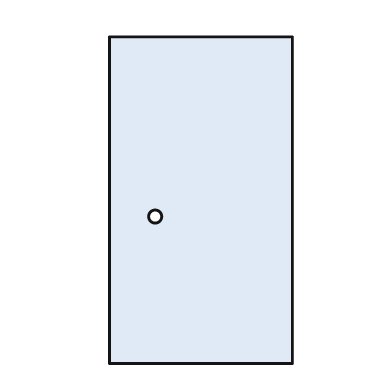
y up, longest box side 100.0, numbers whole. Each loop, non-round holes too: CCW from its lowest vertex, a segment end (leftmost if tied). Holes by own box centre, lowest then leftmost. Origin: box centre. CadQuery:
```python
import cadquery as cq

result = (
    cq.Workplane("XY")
    .moveTo(-28.0, -50.0)
    .lineTo(28.0, -50.0)
    .lineTo(28.0, 50.0)
    .lineTo(-28.0, 50.0)
    .close()
    .moveTo(-14.0, -5.0)
    .circle(2.0)
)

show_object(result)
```